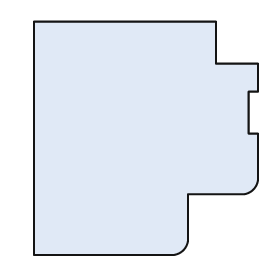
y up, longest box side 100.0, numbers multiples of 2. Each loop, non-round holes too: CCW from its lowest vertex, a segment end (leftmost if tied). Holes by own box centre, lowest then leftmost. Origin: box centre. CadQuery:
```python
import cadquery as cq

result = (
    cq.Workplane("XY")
    .moveTo(-48.0, -50.0)
    .lineTo(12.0, -50.0)
    .threePointArc((16.0, -48.0), (18.0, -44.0))
    .lineTo(18.0, -24.0)
    .lineTo(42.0, -24.0)
    .threePointArc((46.0, -22.0), (48.0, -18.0))
    .lineTo(48.0, 2.0)
    .lineTo(44.0, 2.0)
    .lineTo(44.0, 20.0)
    .lineTo(48.0, 20.0)
    .lineTo(48.0, 32.0)
    .lineTo(30.0, 32.0)
    .lineTo(30.0, 50.0)
    .lineTo(-48.0, 50.0)
    .close()
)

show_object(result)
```